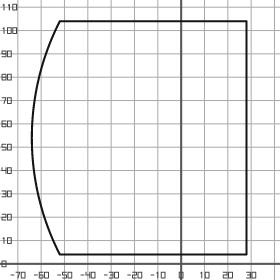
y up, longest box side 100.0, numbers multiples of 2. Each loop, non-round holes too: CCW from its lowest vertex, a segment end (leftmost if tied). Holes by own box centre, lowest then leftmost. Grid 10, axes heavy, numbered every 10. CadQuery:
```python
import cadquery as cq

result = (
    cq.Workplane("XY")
    .moveTo(-52.0, 4.0)
    .lineTo(28.0, 4.0)
    .lineTo(28.0, 104.0)
    .lineTo(-52.0, 104.0)
    .threePointArc((-64.0, 54.0), (-52.0, 4.0))
    .close()
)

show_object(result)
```